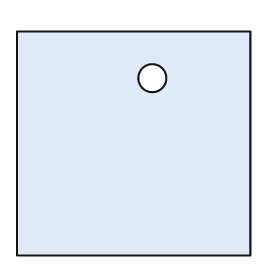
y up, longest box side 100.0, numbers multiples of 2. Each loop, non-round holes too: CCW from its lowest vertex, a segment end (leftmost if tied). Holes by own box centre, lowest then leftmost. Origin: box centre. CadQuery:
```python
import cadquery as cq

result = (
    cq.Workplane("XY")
    .moveTo(-50.0, -48.0)
    .lineTo(50.0, -48.0)
    .lineTo(50.0, 48.0)
    .lineTo(-50.0, 48.0)
    .close()
    .moveTo(8.0, 28.0)
    .circle(6.0)
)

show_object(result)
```